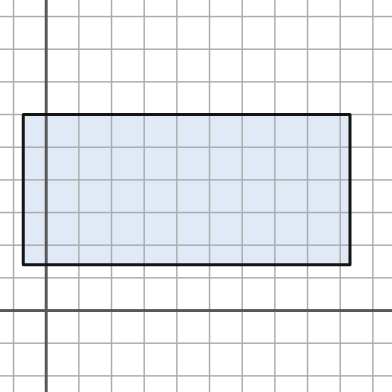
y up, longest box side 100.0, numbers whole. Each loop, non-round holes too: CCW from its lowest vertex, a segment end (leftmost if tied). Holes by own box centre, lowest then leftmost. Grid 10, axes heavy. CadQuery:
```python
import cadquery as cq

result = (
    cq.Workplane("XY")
    .moveTo(-7.0, 14.0)
    .lineTo(93.0, 14.0)
    .lineTo(93.0, 60.0)
    .lineTo(-7.0, 60.0)
    .close()
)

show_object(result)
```